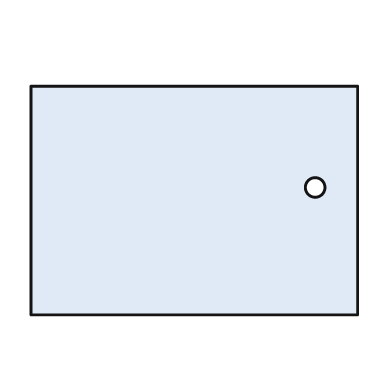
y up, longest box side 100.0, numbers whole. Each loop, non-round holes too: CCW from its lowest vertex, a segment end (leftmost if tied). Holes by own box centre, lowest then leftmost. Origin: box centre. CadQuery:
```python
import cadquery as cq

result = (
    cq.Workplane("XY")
    .moveTo(-50.0, -35.0)
    .lineTo(50.0, -35.0)
    .lineTo(50.0, 35.0)
    .lineTo(-50.0, 35.0)
    .close()
    .moveTo(37.0, 4.0)
    .circle(3.0)
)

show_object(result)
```